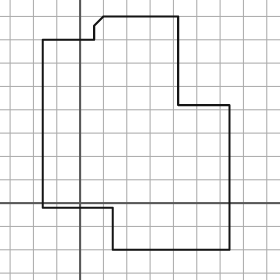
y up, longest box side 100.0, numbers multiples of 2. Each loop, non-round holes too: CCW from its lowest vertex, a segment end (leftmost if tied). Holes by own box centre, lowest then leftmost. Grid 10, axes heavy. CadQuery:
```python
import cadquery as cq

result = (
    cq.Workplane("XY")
    .moveTo(14.0, -20.0)
    .lineTo(64.0, -20.0)
    .lineTo(64.0, 42.0)
    .lineTo(42.0, 42.0)
    .lineTo(42.0, 80.0)
    .lineTo(10.0, 80.0)
    .lineTo(6.0, 76.0)
    .lineTo(6.0, 70.0)
    .lineTo(-16.0, 70.0)
    .lineTo(-16.0, -2.0)
    .lineTo(14.0, -2.0)
    .close()
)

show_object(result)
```